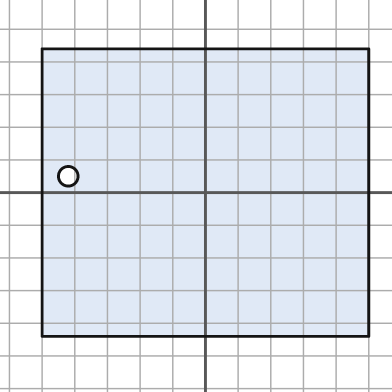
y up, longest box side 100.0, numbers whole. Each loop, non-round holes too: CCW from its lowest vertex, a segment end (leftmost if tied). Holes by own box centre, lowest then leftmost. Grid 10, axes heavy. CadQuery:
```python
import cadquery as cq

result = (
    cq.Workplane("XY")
    .moveTo(-50.0, -44.0)
    .lineTo(50.0, -44.0)
    .lineTo(50.0, 44.0)
    .lineTo(-50.0, 44.0)
    .close()
    .moveTo(-42.0, 5.0)
    .circle(3.0)
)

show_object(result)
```